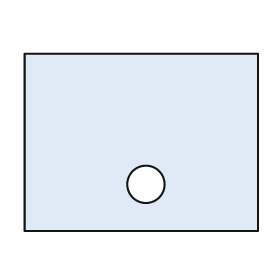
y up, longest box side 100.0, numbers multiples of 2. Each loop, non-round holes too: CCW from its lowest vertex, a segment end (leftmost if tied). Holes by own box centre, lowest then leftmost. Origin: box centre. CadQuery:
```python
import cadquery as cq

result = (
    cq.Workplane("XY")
    .moveTo(-50.0, -38.0)
    .lineTo(50.0, -38.0)
    .lineTo(50.0, 38.0)
    .lineTo(-50.0, 38.0)
    .close()
    .moveTo(2.0, -18.0)
    .circle(8.0)
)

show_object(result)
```